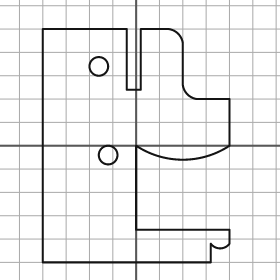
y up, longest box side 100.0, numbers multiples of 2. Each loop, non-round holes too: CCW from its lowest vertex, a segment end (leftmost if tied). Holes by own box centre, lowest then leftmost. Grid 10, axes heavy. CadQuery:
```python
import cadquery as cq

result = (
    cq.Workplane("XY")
    .moveTo(-40.0, -50.0)
    .lineTo(32.0, -50.0)
    .lineTo(32.0, -42.0)
    .threePointArc((36.0, -44.0), (40.0, -42.0))
    .lineTo(40.0, -36.0)
    .lineTo(0.0, -36.0)
    .lineTo(0.0, 0.0)
    .threePointArc((20.0, -6.0), (40.0, 0.0))
    .lineTo(40.0, 20.0)
    .lineTo(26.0, 20.0)
    .threePointArc((22.0, 22.0), (20.0, 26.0))
    .lineTo(20.0, 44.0)
    .threePointArc((18.0, 48.0), (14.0, 50.0))
    .lineTo(2.0, 50.0)
    .lineTo(2.0, 24.0)
    .lineTo(-4.0, 24.0)
    .lineTo(-4.0, 50.0)
    .lineTo(-40.0, 50.0)
    .close()
    .moveTo(-12.0, -4.0)
    .circle(4.0)
    .moveTo(-16.0, 34.0)
    .circle(4.0)
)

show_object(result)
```